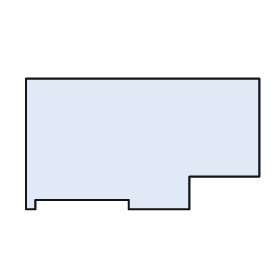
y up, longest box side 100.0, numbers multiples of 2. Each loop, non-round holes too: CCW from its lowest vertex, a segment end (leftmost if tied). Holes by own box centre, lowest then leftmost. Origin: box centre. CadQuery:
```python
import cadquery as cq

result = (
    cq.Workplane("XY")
    .moveTo(-50.0, -28.0)
    .lineTo(-46.0, -28.0)
    .lineTo(-46.0, -24.0)
    .lineTo(-6.0, -24.0)
    .lineTo(-6.0, -28.0)
    .lineTo(20.0, -28.0)
    .lineTo(20.0, -14.0)
    .lineTo(50.0, -14.0)
    .lineTo(50.0, 28.0)
    .lineTo(-50.0, 28.0)
    .close()
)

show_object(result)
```